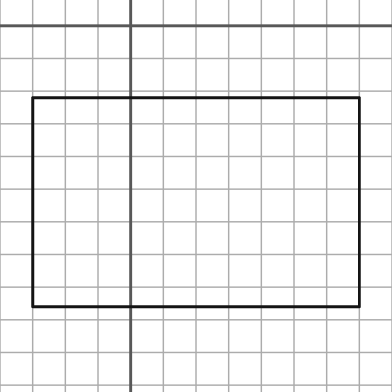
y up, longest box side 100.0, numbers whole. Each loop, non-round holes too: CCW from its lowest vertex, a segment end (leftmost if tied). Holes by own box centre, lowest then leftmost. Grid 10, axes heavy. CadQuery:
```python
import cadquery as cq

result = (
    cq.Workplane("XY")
    .moveTo(-30.0, -86.0)
    .lineTo(70.0, -86.0)
    .lineTo(70.0, -22.0)
    .lineTo(-30.0, -22.0)
    .close()
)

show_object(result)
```